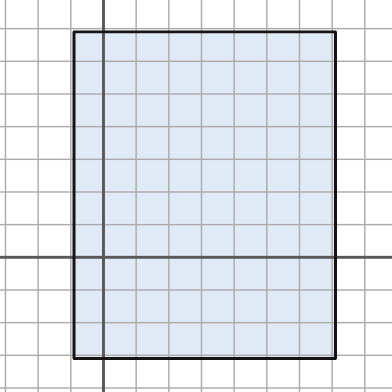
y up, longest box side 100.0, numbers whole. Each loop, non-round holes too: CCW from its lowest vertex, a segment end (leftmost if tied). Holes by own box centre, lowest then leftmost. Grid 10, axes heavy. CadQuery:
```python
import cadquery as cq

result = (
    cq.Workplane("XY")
    .moveTo(-9.0, -31.0)
    .lineTo(71.0, -31.0)
    .lineTo(71.0, 69.0)
    .lineTo(-9.0, 69.0)
    .close()
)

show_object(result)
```